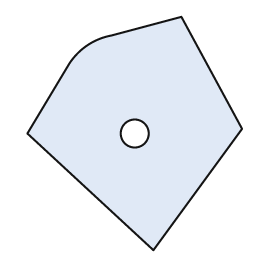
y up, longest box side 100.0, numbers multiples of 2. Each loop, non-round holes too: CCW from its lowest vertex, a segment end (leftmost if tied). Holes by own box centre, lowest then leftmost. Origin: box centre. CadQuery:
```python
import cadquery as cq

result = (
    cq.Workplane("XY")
    .moveTo(8.0, -50.0)
    .lineTo(46.0, 2.0)
    .lineTo(20.0, 50.0)
    .lineTo(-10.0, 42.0)
    .threePointArc((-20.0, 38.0), (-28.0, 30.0))
    .lineTo(-46.0, 0.0)
    .close()
    .moveTo(0.0, 0.0)
    .circle(6.0)
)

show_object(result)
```